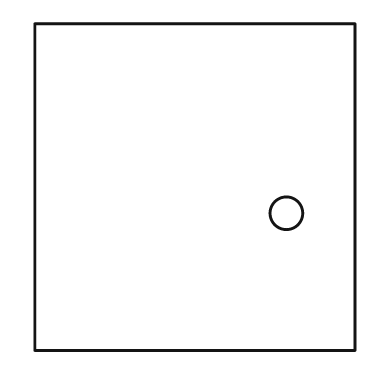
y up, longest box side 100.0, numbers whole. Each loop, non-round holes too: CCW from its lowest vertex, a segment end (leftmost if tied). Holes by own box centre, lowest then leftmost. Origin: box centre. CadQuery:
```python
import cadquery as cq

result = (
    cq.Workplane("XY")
    .moveTo(-49.0, -50.0)
    .lineTo(49.0, -50.0)
    .lineTo(49.0, 50.0)
    .lineTo(-49.0, 50.0)
    .close()
    .moveTo(28.0, -8.0)
    .circle(5.0)
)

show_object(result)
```